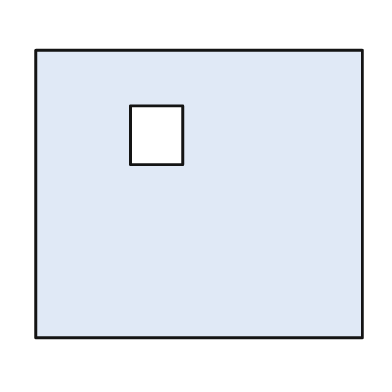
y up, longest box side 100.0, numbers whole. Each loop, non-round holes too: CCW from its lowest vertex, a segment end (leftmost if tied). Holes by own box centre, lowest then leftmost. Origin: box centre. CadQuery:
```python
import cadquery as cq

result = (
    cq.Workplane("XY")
    .moveTo(-50.0, -44.0)
    .lineTo(50.0, -44.0)
    .lineTo(50.0, 44.0)
    .lineTo(-50.0, 44.0)
    .close()
    .moveTo(-21.0, 9.0)
    .lineTo(-5.0, 9.0)
    .lineTo(-5.0, 27.0)
    .lineTo(-21.0, 27.0)
    .close()
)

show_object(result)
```